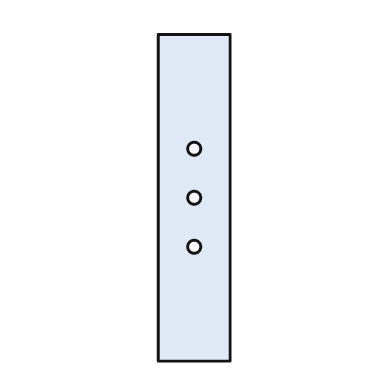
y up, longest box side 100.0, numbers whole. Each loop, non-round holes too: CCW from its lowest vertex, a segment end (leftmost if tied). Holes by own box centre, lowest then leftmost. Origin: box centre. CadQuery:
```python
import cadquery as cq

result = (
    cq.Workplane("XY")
    .moveTo(-11.0, -50.0)
    .lineTo(11.0, -50.0)
    .lineTo(11.0, 50.0)
    .lineTo(-11.0, 50.0)
    .close()
    .moveTo(0.0, -15.0)
    .circle(2.0)
    .moveTo(0.0, 0.0)
    .circle(2.0)
    .moveTo(0.0, 15.0)
    .circle(2.0)
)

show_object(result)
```